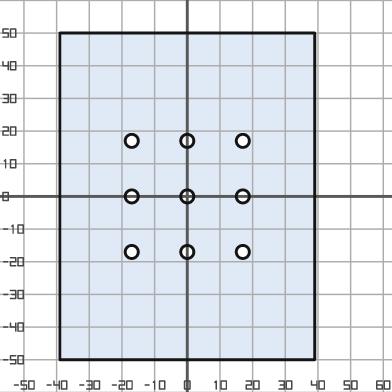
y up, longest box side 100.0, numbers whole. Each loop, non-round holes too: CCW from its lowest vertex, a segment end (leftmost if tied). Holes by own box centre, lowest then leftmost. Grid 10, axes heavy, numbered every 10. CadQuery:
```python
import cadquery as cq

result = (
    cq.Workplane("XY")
    .moveTo(-39.0, -50.0)
    .lineTo(39.0, -50.0)
    .lineTo(39.0, 50.0)
    .lineTo(-39.0, 50.0)
    .close()
    .moveTo(-17.0, -17.0)
    .circle(2.0)
    .moveTo(0.0, -17.0)
    .circle(2.0)
    .moveTo(17.0, -17.0)
    .circle(2.0)
    .moveTo(-17.0, 0.0)
    .circle(2.0)
    .moveTo(0.0, 0.0)
    .circle(2.0)
    .moveTo(17.0, 0.0)
    .circle(2.0)
    .moveTo(-17.0, 17.0)
    .circle(2.0)
    .moveTo(0.0, 17.0)
    .circle(2.0)
    .moveTo(17.0, 17.0)
    .circle(2.0)
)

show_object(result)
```